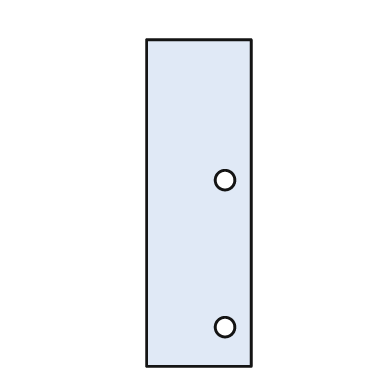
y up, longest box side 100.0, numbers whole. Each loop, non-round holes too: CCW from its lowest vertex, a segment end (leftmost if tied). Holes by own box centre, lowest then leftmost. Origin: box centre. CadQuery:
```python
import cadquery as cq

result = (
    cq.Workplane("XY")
    .moveTo(-16.0, -50.0)
    .lineTo(16.0, -50.0)
    .lineTo(16.0, 50.0)
    .lineTo(-16.0, 50.0)
    .close()
    .moveTo(8.0, -38.0)
    .circle(3.0)
    .moveTo(8.0, 7.0)
    .circle(3.0)
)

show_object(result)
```